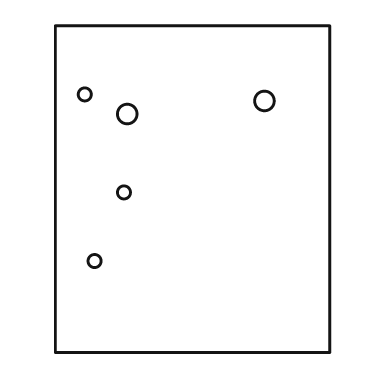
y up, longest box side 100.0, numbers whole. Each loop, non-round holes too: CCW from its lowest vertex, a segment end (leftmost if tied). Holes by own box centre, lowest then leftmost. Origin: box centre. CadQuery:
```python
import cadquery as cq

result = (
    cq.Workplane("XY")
    .moveTo(-42.0, -50.0)
    .lineTo(42.0, -50.0)
    .lineTo(42.0, 50.0)
    .lineTo(-42.0, 50.0)
    .close()
    .moveTo(-30.0, -22.0)
    .circle(2.0)
    .moveTo(-21.0, -1.0)
    .circle(2.0)
    .moveTo(-20.0, 23.0)
    .circle(3.0)
    .moveTo(22.0, 27.0)
    .circle(3.0)
    .moveTo(-33.0, 29.0)
    .circle(2.0)
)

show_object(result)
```